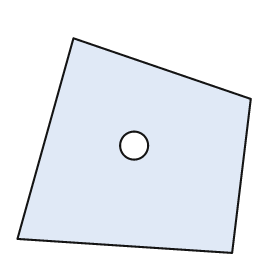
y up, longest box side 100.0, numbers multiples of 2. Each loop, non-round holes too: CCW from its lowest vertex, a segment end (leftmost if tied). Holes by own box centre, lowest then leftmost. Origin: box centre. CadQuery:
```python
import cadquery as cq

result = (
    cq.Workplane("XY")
    .moveTo(42.0, -46.0)
    .lineTo(50.0, 20.0)
    .lineTo(-26.0, 46.0)
    .lineTo(-50.0, -40.0)
    .close()
    .moveTo(0.0, 0.0)
    .circle(6.0)
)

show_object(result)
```